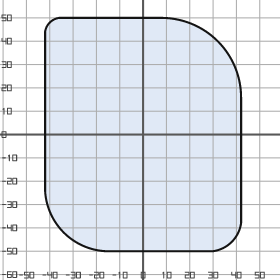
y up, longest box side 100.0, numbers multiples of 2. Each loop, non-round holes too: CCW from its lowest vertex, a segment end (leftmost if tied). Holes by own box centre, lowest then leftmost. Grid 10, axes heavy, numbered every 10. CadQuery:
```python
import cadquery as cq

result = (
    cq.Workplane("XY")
    .moveTo(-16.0, -50.0)
    .lineTo(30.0, -50.0)
    .threePointArc((38.0, -46.0), (42.0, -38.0))
    .lineTo(42.0, 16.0)
    .threePointArc((32.0, 40.0), (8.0, 50.0))
    .lineTo(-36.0, 50.0)
    .threePointArc((-40.0, 48.0), (-42.0, 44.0))
    .lineTo(-42.0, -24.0)
    .threePointArc((-34.0, -42.0), (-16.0, -50.0))
    .close()
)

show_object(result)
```